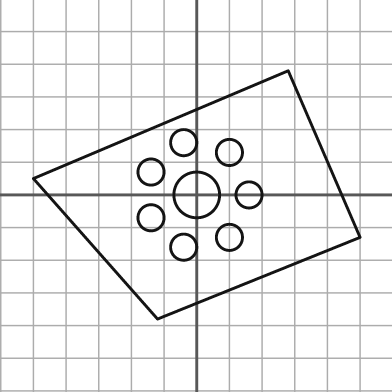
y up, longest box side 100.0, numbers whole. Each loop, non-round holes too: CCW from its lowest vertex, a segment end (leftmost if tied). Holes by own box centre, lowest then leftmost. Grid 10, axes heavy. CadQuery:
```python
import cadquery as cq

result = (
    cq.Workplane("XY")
    .moveTo(-12.0, -38.0)
    .lineTo(50.0, -13.0)
    .lineTo(28.0, 38.0)
    .lineTo(-50.0, 5.0)
    .close()
    .moveTo(-4.0, -16.0)
    .circle(4.0)
    .moveTo(10.0, -13.0)
    .circle(4.0)
    .moveTo(-14.0, -7.0)
    .circle(4.0)
    .moveTo(0.0, 0.0)
    .circle(7.0)
    .moveTo(16.0, 0.0)
    .circle(4.0)
    .moveTo(-14.0, 7.0)
    .circle(4.0)
    .moveTo(10.0, 13.0)
    .circle(4.0)
    .moveTo(-4.0, 16.0)
    .circle(4.0)
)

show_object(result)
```